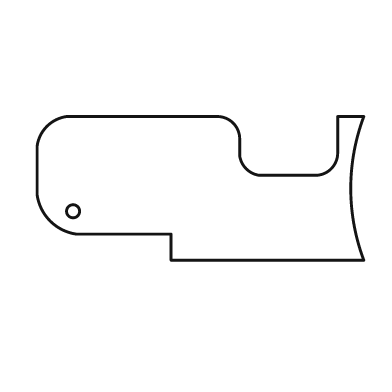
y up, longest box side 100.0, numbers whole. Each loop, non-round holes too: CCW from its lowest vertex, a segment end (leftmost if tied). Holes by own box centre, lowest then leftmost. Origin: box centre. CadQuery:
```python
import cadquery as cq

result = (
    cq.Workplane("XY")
    .moveTo(-9.0, -22.0)
    .lineTo(50.0, -22.0)
    .threePointArc((46.0, 0.0), (50.0, 22.0))
    .lineTo(42.0, 22.0)
    .lineTo(42.0, 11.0)
    .threePointArc((40.0, 6.0), (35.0, 4.0))
    .lineTo(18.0, 4.0)
    .threePointArc((14.0, 6.0), (12.0, 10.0))
    .lineTo(12.0, 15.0)
    .threePointArc((10.0, 20.0), (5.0, 22.0))
    .lineTo(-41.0, 22.0)
    .threePointArc((-47.0, 19.0), (-50.0, 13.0))
    .lineTo(-50.0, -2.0)
    .threePointArc((-46.0, -10.0), (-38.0, -14.0))
    .lineTo(-9.0, -14.0)
    .close()
    .moveTo(-39.0, -7.0)
    .circle(2.0)
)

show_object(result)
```